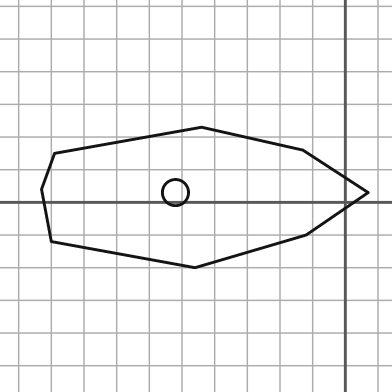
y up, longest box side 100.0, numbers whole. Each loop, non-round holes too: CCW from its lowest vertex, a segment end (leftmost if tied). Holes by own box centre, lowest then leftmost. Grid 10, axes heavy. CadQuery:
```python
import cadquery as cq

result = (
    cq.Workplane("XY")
    .moveTo(-46.0, -20.0)
    .lineTo(-12.0, -10.0)
    .lineTo(7.0, 3.0)
    .lineTo(-13.0, 16.0)
    .lineTo(-44.0, 23.0)
    .lineTo(-89.0, 15.0)
    .lineTo(-93.0, 4.0)
    .lineTo(-90.0, -12.0)
    .close()
    .moveTo(-52.0, 3.0)
    .circle(4.0)
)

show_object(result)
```